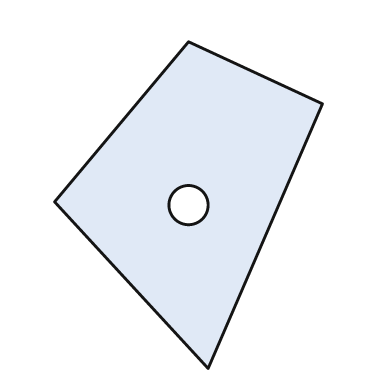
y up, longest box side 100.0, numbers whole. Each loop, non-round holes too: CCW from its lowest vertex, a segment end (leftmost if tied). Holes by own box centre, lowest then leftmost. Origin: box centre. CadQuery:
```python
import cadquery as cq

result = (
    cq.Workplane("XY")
    .moveTo(6.0, -50.0)
    .lineTo(41.0, 31.0)
    .lineTo(0.0, 50.0)
    .lineTo(-41.0, 1.0)
    .close()
    .moveTo(0.0, 0.0)
    .circle(6.0)
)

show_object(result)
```